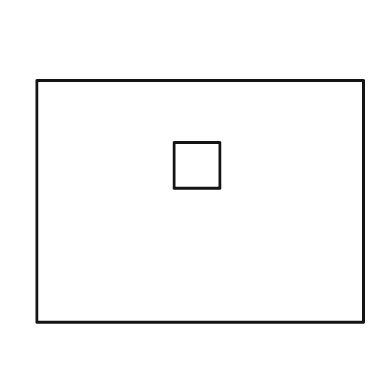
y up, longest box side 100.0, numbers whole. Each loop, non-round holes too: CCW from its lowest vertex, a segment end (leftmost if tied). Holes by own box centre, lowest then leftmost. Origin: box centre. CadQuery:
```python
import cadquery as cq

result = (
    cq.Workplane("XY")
    .moveTo(-50.0, -37.0)
    .lineTo(50.0, -37.0)
    .lineTo(50.0, 37.0)
    .lineTo(-50.0, 37.0)
    .close()
    .moveTo(-8.0, 4.0)
    .lineTo(6.0, 4.0)
    .lineTo(6.0, 18.0)
    .lineTo(-8.0, 18.0)
    .close()
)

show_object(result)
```